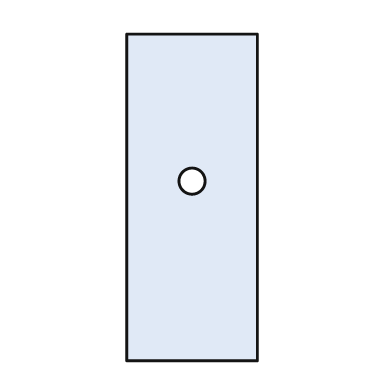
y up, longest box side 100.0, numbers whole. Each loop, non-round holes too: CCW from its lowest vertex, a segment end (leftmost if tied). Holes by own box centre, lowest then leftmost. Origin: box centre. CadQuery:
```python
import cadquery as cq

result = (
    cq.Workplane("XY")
    .moveTo(-20.0, -50.0)
    .lineTo(20.0, -50.0)
    .lineTo(20.0, 50.0)
    .lineTo(-20.0, 50.0)
    .close()
    .moveTo(0.0, 5.0)
    .circle(4.0)
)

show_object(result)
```